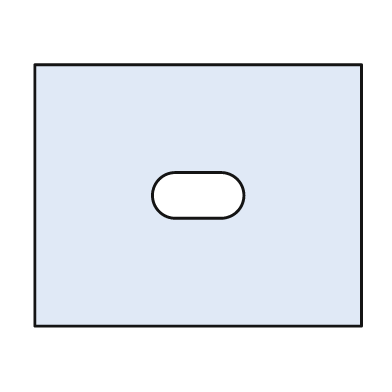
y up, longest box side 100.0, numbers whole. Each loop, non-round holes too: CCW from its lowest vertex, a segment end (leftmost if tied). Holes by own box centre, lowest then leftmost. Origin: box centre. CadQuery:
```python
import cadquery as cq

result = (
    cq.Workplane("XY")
    .moveTo(-50.0, -40.0)
    .lineTo(50.0, -40.0)
    .lineTo(50.0, 40.0)
    .lineTo(-50.0, 40.0)
    .close()
    .moveTo(-7.0, -7.0)
    .lineTo(7.0, -7.0)
    .threePointArc((14.0, 0.0), (7.0, 7.0))
    .lineTo(-7.0, 7.0)
    .threePointArc((-14.0, 0.0), (-7.0, -7.0))
    .close()
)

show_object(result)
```